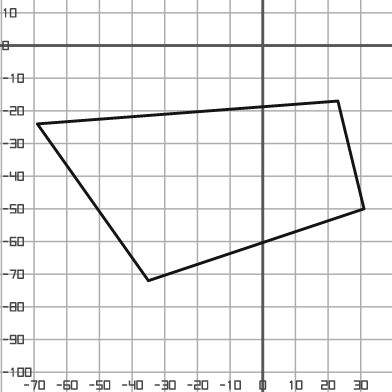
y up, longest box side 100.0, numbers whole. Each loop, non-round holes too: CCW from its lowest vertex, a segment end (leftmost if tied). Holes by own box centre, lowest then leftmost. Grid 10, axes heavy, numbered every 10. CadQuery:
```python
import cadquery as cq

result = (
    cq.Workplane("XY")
    .moveTo(-35.0, -72.0)
    .lineTo(31.0, -50.0)
    .lineTo(23.0, -17.0)
    .lineTo(-69.0, -24.0)
    .close()
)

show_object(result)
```